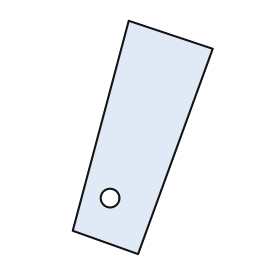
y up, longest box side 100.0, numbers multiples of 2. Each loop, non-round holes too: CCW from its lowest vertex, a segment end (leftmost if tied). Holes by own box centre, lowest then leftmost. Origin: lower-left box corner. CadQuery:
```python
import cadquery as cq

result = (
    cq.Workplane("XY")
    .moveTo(28.0, 0.0)
    .lineTo(60.0, 88.0)
    .lineTo(24.0, 100.0)
    .lineTo(0.0, 10.0)
    .close()
    .moveTo(16.0, 24.0)
    .circle(4.0)
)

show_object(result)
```